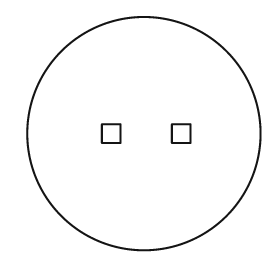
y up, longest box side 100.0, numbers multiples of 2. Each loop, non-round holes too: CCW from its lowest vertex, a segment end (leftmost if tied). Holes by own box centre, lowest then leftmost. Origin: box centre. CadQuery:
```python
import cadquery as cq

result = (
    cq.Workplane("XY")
    .moveTo(0.0, 0.0)
    .circle(50.0)
    .moveTo(-18.0, -4.0)
    .lineTo(-10.0, -4.0)
    .lineTo(-10.0, 4.0)
    .lineTo(-18.0, 4.0)
    .close()
    .moveTo(12.0, -4.0)
    .lineTo(20.0, -4.0)
    .lineTo(20.0, 4.0)
    .lineTo(12.0, 4.0)
    .close()
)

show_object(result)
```